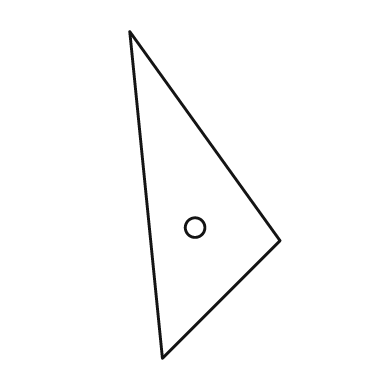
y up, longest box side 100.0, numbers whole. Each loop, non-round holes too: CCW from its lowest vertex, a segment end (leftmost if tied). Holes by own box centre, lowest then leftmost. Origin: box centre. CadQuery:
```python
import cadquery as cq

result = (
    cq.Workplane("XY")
    .moveTo(-13.0, -50.0)
    .lineTo(23.0, -14.0)
    .lineTo(-23.0, 50.0)
    .close()
    .moveTo(-3.0, -10.0)
    .circle(3.0)
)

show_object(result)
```